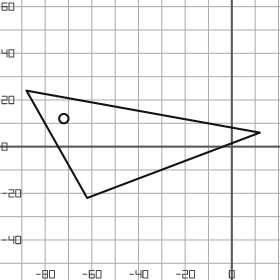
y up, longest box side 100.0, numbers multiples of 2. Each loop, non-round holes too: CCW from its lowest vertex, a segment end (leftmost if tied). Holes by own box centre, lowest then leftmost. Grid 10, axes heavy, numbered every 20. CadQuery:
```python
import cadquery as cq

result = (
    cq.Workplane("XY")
    .moveTo(-62.0, -22.0)
    .lineTo(12.0, 6.0)
    .lineTo(-88.0, 24.0)
    .close()
    .moveTo(-72.0, 12.0)
    .circle(2.0)
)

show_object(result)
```